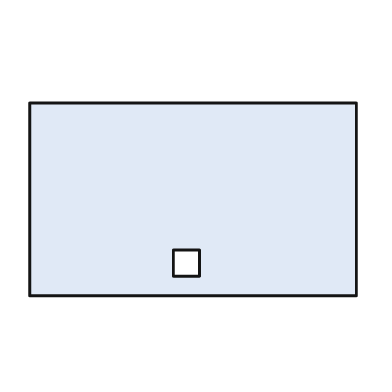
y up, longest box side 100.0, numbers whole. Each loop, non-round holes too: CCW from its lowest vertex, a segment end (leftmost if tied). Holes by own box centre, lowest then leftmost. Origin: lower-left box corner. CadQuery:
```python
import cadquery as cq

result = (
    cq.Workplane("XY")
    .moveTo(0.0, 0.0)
    .lineTo(100.0, 0.0)
    .lineTo(100.0, 59.0)
    .lineTo(0.0, 59.0)
    .close()
    .moveTo(44.0, 6.0)
    .lineTo(52.0, 6.0)
    .lineTo(52.0, 14.0)
    .lineTo(44.0, 14.0)
    .close()
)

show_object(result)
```